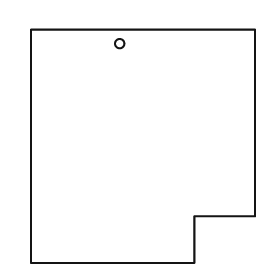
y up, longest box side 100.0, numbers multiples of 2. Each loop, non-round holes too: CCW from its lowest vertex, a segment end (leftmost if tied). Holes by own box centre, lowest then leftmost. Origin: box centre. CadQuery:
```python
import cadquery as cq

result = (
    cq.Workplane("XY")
    .moveTo(-48.0, -50.0)
    .lineTo(22.0, -50.0)
    .lineTo(22.0, -30.0)
    .lineTo(48.0, -30.0)
    .lineTo(48.0, 50.0)
    .lineTo(-48.0, 50.0)
    .close()
    .moveTo(-10.0, 44.0)
    .circle(2.0)
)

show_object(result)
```